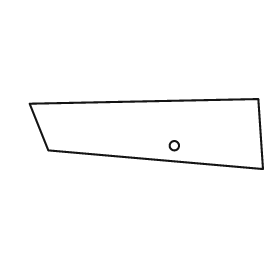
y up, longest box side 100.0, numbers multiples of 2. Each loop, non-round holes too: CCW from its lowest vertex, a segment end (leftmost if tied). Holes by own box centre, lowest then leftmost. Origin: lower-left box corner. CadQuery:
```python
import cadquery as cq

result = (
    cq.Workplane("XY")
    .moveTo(100.0, 0.0)
    .lineTo(98.0, 30.0)
    .lineTo(0.0, 28.0)
    .lineTo(8.0, 8.0)
    .close()
    .moveTo(62.0, 10.0)
    .circle(2.0)
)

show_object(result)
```